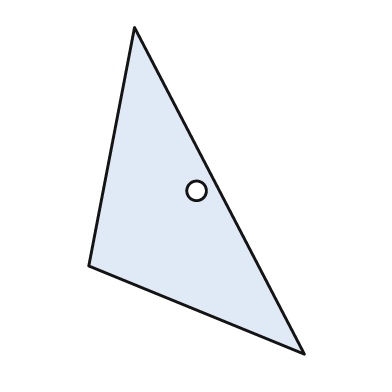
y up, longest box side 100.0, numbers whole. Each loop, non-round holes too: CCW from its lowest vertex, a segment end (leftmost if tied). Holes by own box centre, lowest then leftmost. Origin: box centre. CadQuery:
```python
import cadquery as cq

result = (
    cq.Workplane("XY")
    .moveTo(33.0, -50.0)
    .lineTo(-19.0, 50.0)
    .lineTo(-33.0, -23.0)
    .close()
    .moveTo(0.0, 0.0)
    .circle(3.0)
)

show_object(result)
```